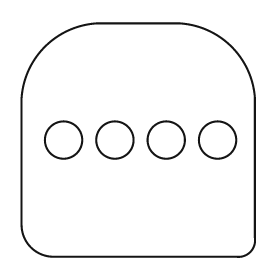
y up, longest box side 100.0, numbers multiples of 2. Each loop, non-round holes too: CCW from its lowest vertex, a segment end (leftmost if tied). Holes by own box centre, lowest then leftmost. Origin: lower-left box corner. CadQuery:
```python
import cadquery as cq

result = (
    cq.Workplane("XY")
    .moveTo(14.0, 0.0)
    .lineTo(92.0, 0.0)
    .threePointArc((98.0, 2.0), (100.0, 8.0))
    .lineTo(100.0, 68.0)
    .threePointArc((90.0, 90.0), (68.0, 100.0))
    .lineTo(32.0, 100.0)
    .threePointArc((10.0, 90.0), (0.0, 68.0))
    .lineTo(0.0, 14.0)
    .threePointArc((4.0, 4.0), (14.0, 0.0))
    .close()
    .moveTo(18.0, 50.0)
    .circle(8.0)
    .moveTo(40.0, 50.0)
    .circle(8.0)
    .moveTo(62.0, 50.0)
    .circle(8.0)
    .moveTo(84.0, 50.0)
    .circle(8.0)
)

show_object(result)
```